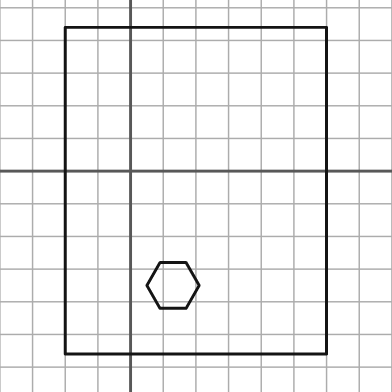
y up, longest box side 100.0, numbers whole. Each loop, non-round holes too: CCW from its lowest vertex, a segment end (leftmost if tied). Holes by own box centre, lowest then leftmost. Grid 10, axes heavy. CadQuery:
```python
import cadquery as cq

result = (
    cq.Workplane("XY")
    .moveTo(-20.0, -56.0)
    .lineTo(60.0, -56.0)
    .lineTo(60.0, 44.0)
    .lineTo(-20.0, 44.0)
    .close()
    .moveTo(9.0, -42.0)
    .lineTo(17.0, -42.0)
    .lineTo(21.0, -35.0)
    .lineTo(17.0, -28.0)
    .lineTo(9.0, -28.0)
    .lineTo(5.0, -35.0)
    .close()
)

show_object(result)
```